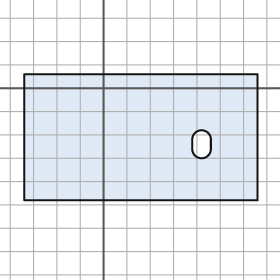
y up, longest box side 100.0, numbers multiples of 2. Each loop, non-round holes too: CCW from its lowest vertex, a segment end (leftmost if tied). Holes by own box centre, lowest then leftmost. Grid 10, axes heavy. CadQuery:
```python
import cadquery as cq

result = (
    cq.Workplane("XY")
    .moveTo(-34.0, -48.0)
    .lineTo(66.0, -48.0)
    .lineTo(66.0, 6.0)
    .lineTo(-34.0, 6.0)
    .close()
    .moveTo(38.0, -26.0)
    .threePointArc((42.0, -30.0), (46.0, -26.0))
    .lineTo(46.0, -22.0)
    .threePointArc((42.0, -18.0), (38.0, -22.0))
    .close()
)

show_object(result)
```